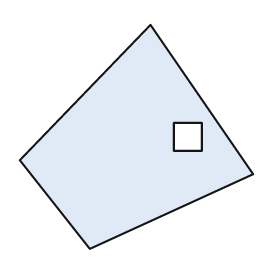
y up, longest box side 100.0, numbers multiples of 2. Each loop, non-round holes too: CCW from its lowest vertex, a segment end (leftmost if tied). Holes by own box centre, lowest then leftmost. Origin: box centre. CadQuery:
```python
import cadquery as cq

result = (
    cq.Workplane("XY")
    .moveTo(-20.0, -48.0)
    .lineTo(50.0, -16.0)
    .lineTo(6.0, 48.0)
    .lineTo(-50.0, -10.0)
    .close()
    .moveTo(16.0, -6.0)
    .lineTo(28.0, -6.0)
    .lineTo(28.0, 6.0)
    .lineTo(16.0, 6.0)
    .close()
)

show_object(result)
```